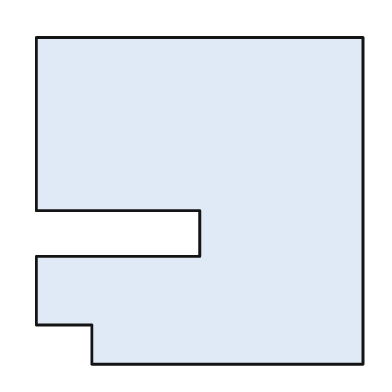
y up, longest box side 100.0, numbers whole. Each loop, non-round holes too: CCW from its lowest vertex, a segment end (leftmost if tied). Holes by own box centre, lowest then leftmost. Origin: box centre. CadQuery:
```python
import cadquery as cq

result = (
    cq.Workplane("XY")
    .moveTo(-33.0, -50.0)
    .lineTo(50.0, -50.0)
    .lineTo(50.0, 50.0)
    .lineTo(-50.0, 50.0)
    .lineTo(-50.0, -3.0)
    .lineTo(0.0, -3.0)
    .lineTo(0.0, -17.0)
    .lineTo(-50.0, -17.0)
    .lineTo(-50.0, -38.0)
    .lineTo(-33.0, -38.0)
    .close()
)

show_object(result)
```